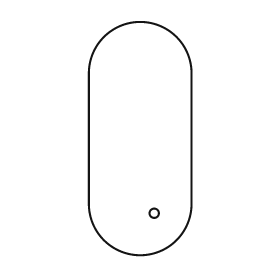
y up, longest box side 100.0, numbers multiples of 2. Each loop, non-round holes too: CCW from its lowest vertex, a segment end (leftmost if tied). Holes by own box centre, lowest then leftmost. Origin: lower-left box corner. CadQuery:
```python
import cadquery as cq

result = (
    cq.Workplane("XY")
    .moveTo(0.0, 22.0)
    .threePointArc((22.0, 0.0), (44.0, 22.0))
    .lineTo(44.0, 78.0)
    .threePointArc((22.0, 100.0), (0.0, 78.0))
    .close()
    .moveTo(28.0, 18.0)
    .circle(2.0)
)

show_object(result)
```